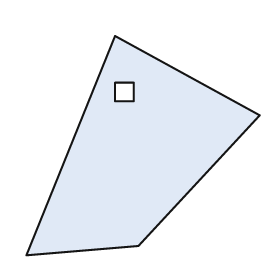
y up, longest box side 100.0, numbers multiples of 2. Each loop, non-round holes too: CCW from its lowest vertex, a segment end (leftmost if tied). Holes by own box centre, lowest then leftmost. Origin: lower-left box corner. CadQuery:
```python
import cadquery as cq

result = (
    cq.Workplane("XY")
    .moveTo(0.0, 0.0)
    .lineTo(48.0, 4.0)
    .lineTo(100.0, 60.0)
    .lineTo(38.0, 94.0)
    .close()
    .moveTo(38.0, 66.0)
    .lineTo(46.0, 66.0)
    .lineTo(46.0, 74.0)
    .lineTo(38.0, 74.0)
    .close()
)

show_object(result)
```